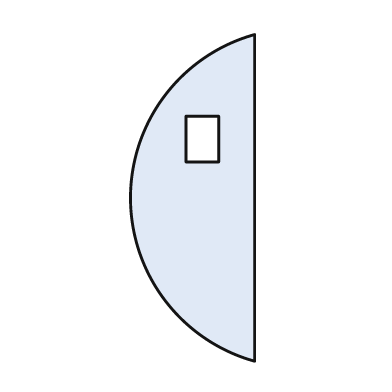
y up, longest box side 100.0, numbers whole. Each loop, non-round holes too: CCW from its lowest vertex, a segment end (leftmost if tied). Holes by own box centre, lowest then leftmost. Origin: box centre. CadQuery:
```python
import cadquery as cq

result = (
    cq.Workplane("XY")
    .moveTo(19.0, -50.0)
    .lineTo(19.0, 50.0)
    .threePointArc((-19.0, 0.0), (19.0, -50.0))
    .close()
    .moveTo(-2.0, 11.0)
    .lineTo(8.0, 11.0)
    .lineTo(8.0, 25.0)
    .lineTo(-2.0, 25.0)
    .close()
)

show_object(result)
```